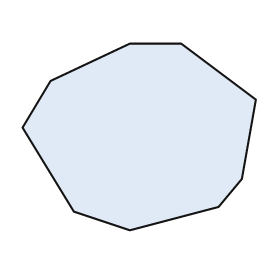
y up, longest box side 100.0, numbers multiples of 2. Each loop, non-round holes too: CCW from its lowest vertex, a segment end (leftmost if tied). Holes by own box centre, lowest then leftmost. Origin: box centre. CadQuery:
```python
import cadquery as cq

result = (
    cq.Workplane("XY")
    .moveTo(-4.0, -40.0)
    .lineTo(34.0, -30.0)
    .lineTo(44.0, -18.0)
    .lineTo(50.0, 16.0)
    .lineTo(18.0, 40.0)
    .lineTo(-4.0, 40.0)
    .lineTo(-38.0, 24.0)
    .lineTo(-50.0, 4.0)
    .lineTo(-28.0, -32.0)
    .close()
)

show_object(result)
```